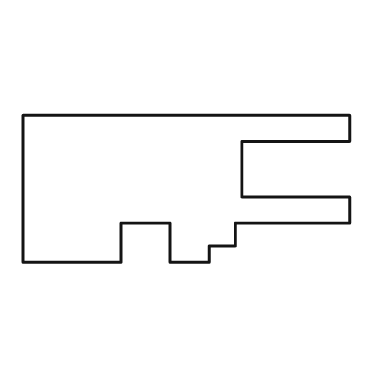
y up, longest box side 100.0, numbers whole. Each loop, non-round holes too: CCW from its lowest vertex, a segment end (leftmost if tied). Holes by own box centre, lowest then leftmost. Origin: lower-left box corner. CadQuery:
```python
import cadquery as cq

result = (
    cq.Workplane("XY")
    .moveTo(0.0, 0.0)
    .lineTo(30.0, 0.0)
    .lineTo(30.0, 12.0)
    .lineTo(45.0, 12.0)
    .lineTo(45.0, 0.0)
    .lineTo(57.0, 0.0)
    .lineTo(57.0, 5.0)
    .lineTo(65.0, 5.0)
    .lineTo(65.0, 12.0)
    .lineTo(100.0, 12.0)
    .lineTo(100.0, 20.0)
    .lineTo(67.0, 20.0)
    .lineTo(67.0, 37.0)
    .lineTo(100.0, 37.0)
    .lineTo(100.0, 45.0)
    .lineTo(0.0, 45.0)
    .close()
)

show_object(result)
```